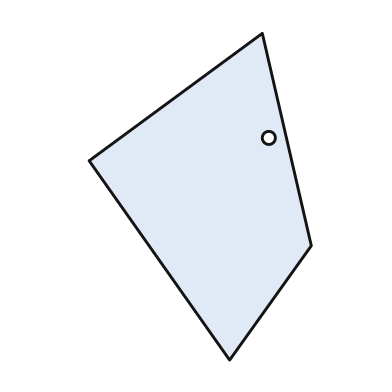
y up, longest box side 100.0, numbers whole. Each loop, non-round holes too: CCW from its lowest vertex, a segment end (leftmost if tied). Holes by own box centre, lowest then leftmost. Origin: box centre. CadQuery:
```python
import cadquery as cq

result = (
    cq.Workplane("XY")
    .moveTo(9.0, -50.0)
    .lineTo(34.0, -15.0)
    .lineTo(19.0, 50.0)
    .lineTo(-34.0, 11.0)
    .close()
    .moveTo(21.0, 18.0)
    .circle(2.0)
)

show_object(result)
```